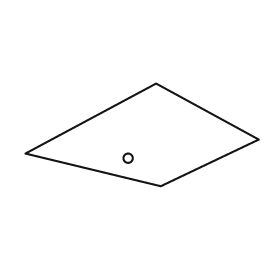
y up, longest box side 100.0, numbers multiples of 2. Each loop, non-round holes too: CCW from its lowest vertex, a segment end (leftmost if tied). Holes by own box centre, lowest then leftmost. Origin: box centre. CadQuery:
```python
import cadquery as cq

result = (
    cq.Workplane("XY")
    .moveTo(8.0, -22.0)
    .lineTo(50.0, -2.0)
    .lineTo(6.0, 22.0)
    .lineTo(-50.0, -8.0)
    .close()
    .moveTo(-6.0, -10.0)
    .circle(2.0)
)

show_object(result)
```